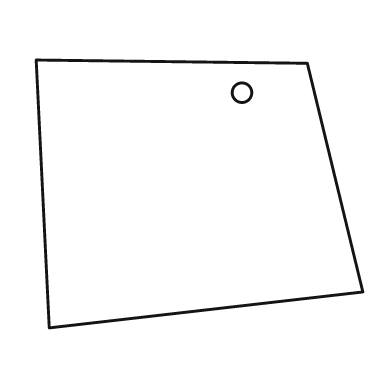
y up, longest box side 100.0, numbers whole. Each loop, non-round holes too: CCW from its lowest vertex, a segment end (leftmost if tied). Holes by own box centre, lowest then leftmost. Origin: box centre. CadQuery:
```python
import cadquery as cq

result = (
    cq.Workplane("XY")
    .moveTo(-46.0, -41.0)
    .lineTo(50.0, -30.0)
    .lineTo(33.0, 40.0)
    .lineTo(-50.0, 41.0)
    .close()
    .moveTo(13.0, 31.0)
    .circle(3.0)
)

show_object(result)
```